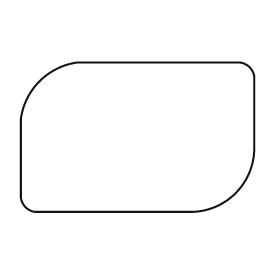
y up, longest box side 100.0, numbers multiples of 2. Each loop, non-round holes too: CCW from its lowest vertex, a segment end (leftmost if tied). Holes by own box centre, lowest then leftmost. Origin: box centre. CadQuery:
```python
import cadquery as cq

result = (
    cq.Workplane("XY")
    .moveTo(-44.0, -32.0)
    .lineTo(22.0, -32.0)
    .threePointArc((42.0, -24.0), (50.0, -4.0))
    .lineTo(50.0, 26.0)
    .threePointArc((48.0, 30.0), (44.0, 32.0))
    .lineTo(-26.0, 32.0)
    .threePointArc((-42.0, 24.0), (-50.0, 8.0))
    .lineTo(-50.0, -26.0)
    .threePointArc((-48.0, -30.0), (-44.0, -32.0))
    .close()
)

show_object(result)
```